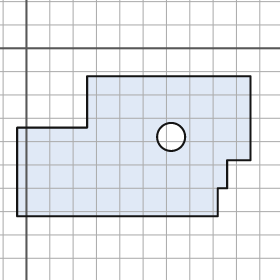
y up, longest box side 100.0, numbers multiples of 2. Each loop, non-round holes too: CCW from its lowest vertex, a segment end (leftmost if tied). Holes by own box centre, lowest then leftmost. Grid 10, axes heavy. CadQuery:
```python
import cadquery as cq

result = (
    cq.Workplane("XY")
    .moveTo(-4.0, -72.0)
    .lineTo(82.0, -72.0)
    .lineTo(82.0, -60.0)
    .lineTo(86.0, -60.0)
    .lineTo(86.0, -48.0)
    .lineTo(96.0, -48.0)
    .lineTo(96.0, -12.0)
    .lineTo(26.0, -12.0)
    .lineTo(26.0, -34.0)
    .lineTo(-4.0, -34.0)
    .close()
    .moveTo(62.0, -38.0)
    .circle(6.0)
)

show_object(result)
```